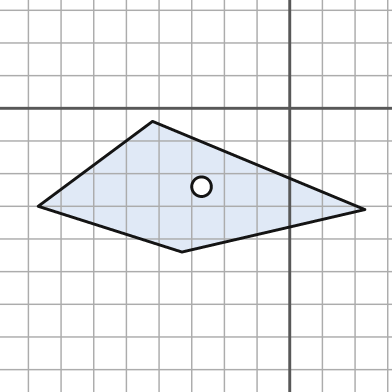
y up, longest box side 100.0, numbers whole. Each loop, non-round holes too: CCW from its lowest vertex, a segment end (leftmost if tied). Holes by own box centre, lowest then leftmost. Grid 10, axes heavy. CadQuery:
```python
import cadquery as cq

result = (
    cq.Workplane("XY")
    .moveTo(-33.0, -44.0)
    .lineTo(23.0, -31.0)
    .lineTo(-42.0, -4.0)
    .lineTo(-77.0, -30.0)
    .close()
    .moveTo(-27.0, -24.0)
    .circle(3.0)
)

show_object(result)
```